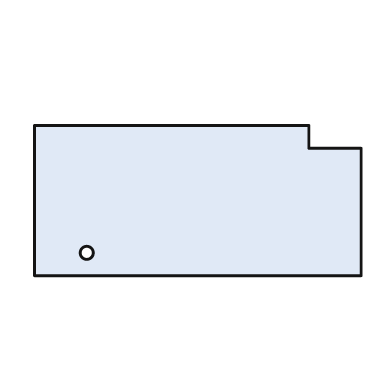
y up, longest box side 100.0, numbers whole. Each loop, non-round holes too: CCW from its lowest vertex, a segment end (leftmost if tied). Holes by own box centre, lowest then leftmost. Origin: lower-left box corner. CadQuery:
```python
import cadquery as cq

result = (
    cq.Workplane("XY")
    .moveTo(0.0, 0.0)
    .lineTo(100.0, 0.0)
    .lineTo(100.0, 39.0)
    .lineTo(84.0, 39.0)
    .lineTo(84.0, 46.0)
    .lineTo(0.0, 46.0)
    .close()
    .moveTo(16.0, 7.0)
    .circle(2.0)
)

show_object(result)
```